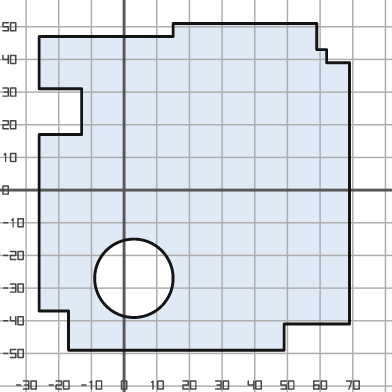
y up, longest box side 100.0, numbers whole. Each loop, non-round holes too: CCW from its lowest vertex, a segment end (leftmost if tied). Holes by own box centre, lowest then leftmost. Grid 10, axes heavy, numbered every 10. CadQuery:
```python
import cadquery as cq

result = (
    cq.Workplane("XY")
    .moveTo(-17.0, -49.0)
    .lineTo(49.0, -49.0)
    .lineTo(49.0, -41.0)
    .lineTo(69.0, -41.0)
    .lineTo(69.0, 39.0)
    .lineTo(62.0, 39.0)
    .lineTo(62.0, 43.0)
    .lineTo(59.0, 43.0)
    .lineTo(59.0, 51.0)
    .lineTo(15.0, 51.0)
    .lineTo(15.0, 47.0)
    .lineTo(-26.0, 47.0)
    .lineTo(-26.0, 31.0)
    .lineTo(-13.0, 31.0)
    .lineTo(-13.0, 17.0)
    .lineTo(-26.0, 17.0)
    .lineTo(-26.0, -37.0)
    .lineTo(-17.0, -37.0)
    .close()
    .moveTo(3.0, -27.0)
    .circle(12.0)
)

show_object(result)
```